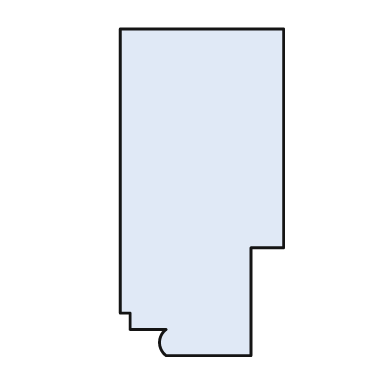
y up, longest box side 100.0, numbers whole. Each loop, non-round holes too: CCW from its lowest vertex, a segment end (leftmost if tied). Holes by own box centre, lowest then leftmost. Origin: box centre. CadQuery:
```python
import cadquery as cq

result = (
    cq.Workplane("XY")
    .moveTo(-11.0, -50.0)
    .lineTo(15.0, -50.0)
    .lineTo(15.0, -17.0)
    .lineTo(25.0, -17.0)
    .lineTo(25.0, 50.0)
    .lineTo(-25.0, 50.0)
    .lineTo(-25.0, -37.0)
    .lineTo(-22.0, -37.0)
    .lineTo(-22.0, -42.0)
    .lineTo(-11.0, -42.0)
    .threePointArc((-13.0, -46.0), (-11.0, -50.0))
    .close()
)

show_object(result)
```